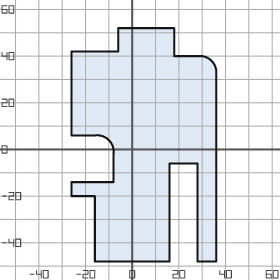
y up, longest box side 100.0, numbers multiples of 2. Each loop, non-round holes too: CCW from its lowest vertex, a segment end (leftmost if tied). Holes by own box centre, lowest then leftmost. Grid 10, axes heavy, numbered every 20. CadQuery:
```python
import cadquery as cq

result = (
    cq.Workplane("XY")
    .moveTo(-16.0, -48.0)
    .lineTo(16.0, -48.0)
    .lineTo(16.0, -6.0)
    .lineTo(28.0, -6.0)
    .lineTo(28.0, -48.0)
    .lineTo(36.0, -48.0)
    .lineTo(36.0, 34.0)
    .threePointArc((34.0, 38.0), (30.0, 40.0))
    .lineTo(18.0, 40.0)
    .lineTo(18.0, 52.0)
    .lineTo(-6.0, 52.0)
    .lineTo(-6.0, 42.0)
    .lineTo(-26.0, 42.0)
    .lineTo(-26.0, 6.0)
    .lineTo(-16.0, 6.0)
    .threePointArc((-10.0, 4.0), (-8.0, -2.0))
    .lineTo(-8.0, -14.0)
    .lineTo(-26.0, -14.0)
    .lineTo(-26.0, -20.0)
    .lineTo(-16.0, -20.0)
    .close()
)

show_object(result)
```